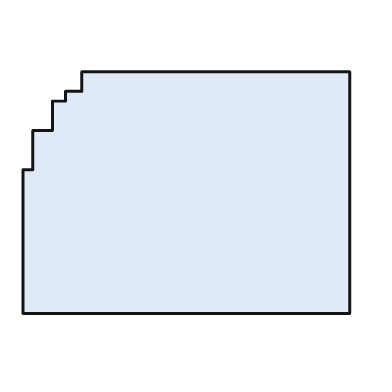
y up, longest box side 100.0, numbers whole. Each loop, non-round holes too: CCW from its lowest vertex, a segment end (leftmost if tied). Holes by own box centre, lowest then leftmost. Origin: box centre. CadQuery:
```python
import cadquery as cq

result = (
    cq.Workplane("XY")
    .moveTo(-50.0, -37.0)
    .lineTo(50.0, -37.0)
    .lineTo(50.0, 37.0)
    .lineTo(-32.0, 37.0)
    .lineTo(-32.0, 31.0)
    .lineTo(-37.0, 31.0)
    .lineTo(-37.0, 28.0)
    .lineTo(-41.0, 28.0)
    .lineTo(-41.0, 19.0)
    .lineTo(-47.0, 19.0)
    .lineTo(-47.0, 7.0)
    .lineTo(-50.0, 7.0)
    .close()
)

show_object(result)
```